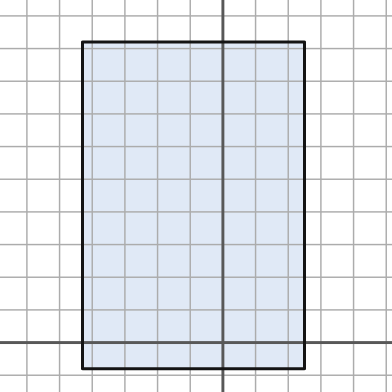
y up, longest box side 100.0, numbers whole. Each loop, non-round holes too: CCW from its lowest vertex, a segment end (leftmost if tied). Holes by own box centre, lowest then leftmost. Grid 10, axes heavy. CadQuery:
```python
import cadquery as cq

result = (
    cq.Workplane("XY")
    .moveTo(-43.0, -8.0)
    .lineTo(25.0, -8.0)
    .lineTo(25.0, 92.0)
    .lineTo(-43.0, 92.0)
    .close()
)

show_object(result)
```